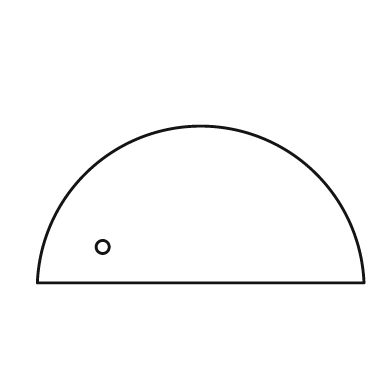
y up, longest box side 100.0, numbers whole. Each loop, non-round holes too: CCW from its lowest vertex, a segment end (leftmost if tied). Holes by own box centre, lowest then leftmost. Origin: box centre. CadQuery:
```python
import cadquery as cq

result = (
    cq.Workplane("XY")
    .moveTo(-50.0, -24.0)
    .lineTo(50.0, -24.0)
    .threePointArc((0.0, 24.0), (-50.0, -24.0))
    .close()
    .moveTo(-30.0, -13.0)
    .circle(2.0)
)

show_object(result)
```